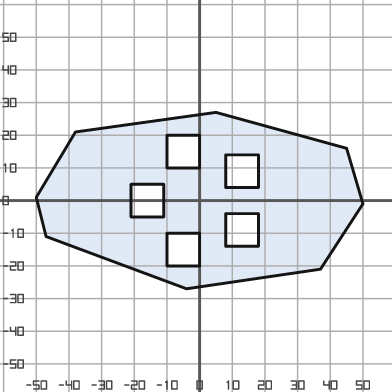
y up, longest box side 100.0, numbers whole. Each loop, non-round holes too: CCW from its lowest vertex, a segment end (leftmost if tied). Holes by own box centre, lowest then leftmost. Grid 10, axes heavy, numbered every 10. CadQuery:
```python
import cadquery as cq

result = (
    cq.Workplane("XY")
    .moveTo(-4.0, -27.0)
    .lineTo(37.0, -21.0)
    .lineTo(50.0, -1.0)
    .lineTo(45.0, 16.0)
    .lineTo(5.0, 27.0)
    .lineTo(-38.0, 21.0)
    .lineTo(-50.0, 1.0)
    .lineTo(-47.0, -11.0)
    .close()
    .moveTo(-10.0, -20.0)
    .lineTo(0.0, -20.0)
    .lineTo(0.0, -10.0)
    .lineTo(-10.0, -10.0)
    .close()
    .moveTo(8.0, -14.0)
    .lineTo(18.0, -14.0)
    .lineTo(18.0, -4.0)
    .lineTo(8.0, -4.0)
    .close()
    .moveTo(-21.0, -5.0)
    .lineTo(-11.0, -5.0)
    .lineTo(-11.0, 5.0)
    .lineTo(-21.0, 5.0)
    .close()
    .moveTo(8.0, 4.0)
    .lineTo(18.0, 4.0)
    .lineTo(18.0, 14.0)
    .lineTo(8.0, 14.0)
    .close()
    .moveTo(-10.0, 10.0)
    .lineTo(0.0, 10.0)
    .lineTo(0.0, 20.0)
    .lineTo(-10.0, 20.0)
    .close()
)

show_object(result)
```